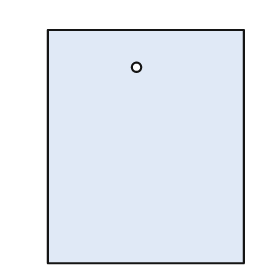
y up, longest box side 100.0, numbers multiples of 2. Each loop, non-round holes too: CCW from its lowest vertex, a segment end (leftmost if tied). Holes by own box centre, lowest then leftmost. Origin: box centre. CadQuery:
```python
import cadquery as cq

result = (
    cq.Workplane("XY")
    .moveTo(-42.0, -50.0)
    .lineTo(42.0, -50.0)
    .lineTo(42.0, 50.0)
    .lineTo(-42.0, 50.0)
    .close()
    .moveTo(-4.0, 34.0)
    .circle(2.0)
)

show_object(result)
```